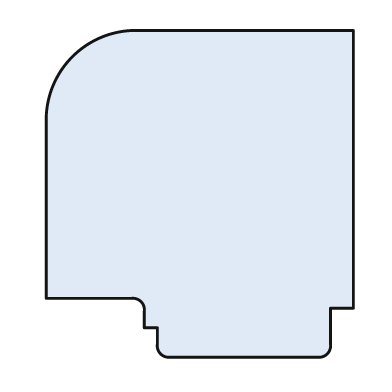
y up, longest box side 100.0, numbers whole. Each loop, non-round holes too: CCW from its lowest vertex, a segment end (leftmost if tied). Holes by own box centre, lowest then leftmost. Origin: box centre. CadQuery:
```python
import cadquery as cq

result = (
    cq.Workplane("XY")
    .moveTo(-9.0, -50.0)
    .lineTo(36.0, -50.0)
    .threePointArc((39.0, -49.0), (40.0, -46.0))
    .lineTo(40.0, -35.0)
    .lineTo(47.0, -35.0)
    .lineTo(47.0, 50.0)
    .lineTo(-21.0, 50.0)
    .threePointArc((-39.0, 42.0), (-47.0, 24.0))
    .lineTo(-47.0, -32.0)
    .lineTo(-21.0, -32.0)
    .threePointArc((-18.0, -33.0), (-17.0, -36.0))
    .lineTo(-17.0, -41.0)
    .lineTo(-13.0, -41.0)
    .lineTo(-13.0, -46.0)
    .threePointArc((-12.0, -49.0), (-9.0, -50.0))
    .close()
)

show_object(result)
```